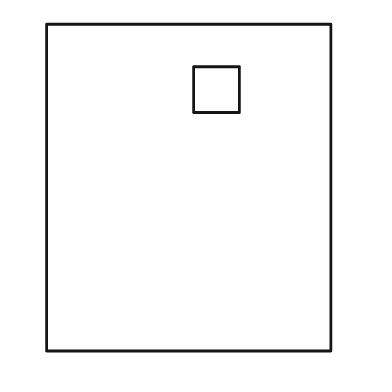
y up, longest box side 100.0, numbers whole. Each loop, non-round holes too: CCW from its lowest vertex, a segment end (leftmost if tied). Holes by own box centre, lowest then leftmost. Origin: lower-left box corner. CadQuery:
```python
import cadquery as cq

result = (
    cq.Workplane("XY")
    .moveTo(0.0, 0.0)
    .lineTo(87.0, 0.0)
    .lineTo(87.0, 100.0)
    .lineTo(0.0, 100.0)
    .close()
    .moveTo(45.0, 73.0)
    .lineTo(59.0, 73.0)
    .lineTo(59.0, 87.0)
    .lineTo(45.0, 87.0)
    .close()
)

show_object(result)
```